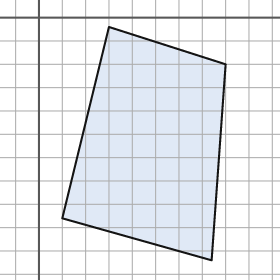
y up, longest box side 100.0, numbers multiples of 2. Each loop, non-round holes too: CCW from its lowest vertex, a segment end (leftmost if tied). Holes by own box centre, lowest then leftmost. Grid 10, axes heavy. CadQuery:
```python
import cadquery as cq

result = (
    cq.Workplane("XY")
    .moveTo(74.0, -104.0)
    .lineTo(80.0, -20.0)
    .lineTo(30.0, -4.0)
    .lineTo(10.0, -86.0)
    .close()
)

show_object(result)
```